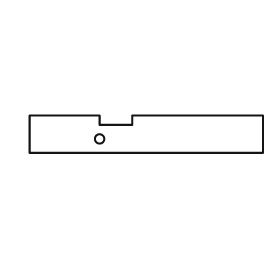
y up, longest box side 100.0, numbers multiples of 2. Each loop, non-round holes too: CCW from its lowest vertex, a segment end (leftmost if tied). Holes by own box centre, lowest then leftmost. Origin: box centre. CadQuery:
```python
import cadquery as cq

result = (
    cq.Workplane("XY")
    .moveTo(-50.0, -8.0)
    .lineTo(50.0, -8.0)
    .lineTo(50.0, 8.0)
    .lineTo(-6.0, 8.0)
    .lineTo(-6.0, 4.0)
    .lineTo(-20.0, 4.0)
    .lineTo(-20.0, 8.0)
    .lineTo(-50.0, 8.0)
    .close()
    .moveTo(-20.0, -2.0)
    .circle(2.0)
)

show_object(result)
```